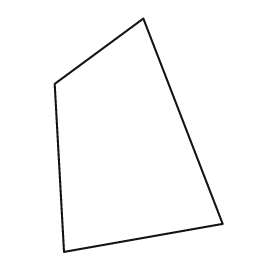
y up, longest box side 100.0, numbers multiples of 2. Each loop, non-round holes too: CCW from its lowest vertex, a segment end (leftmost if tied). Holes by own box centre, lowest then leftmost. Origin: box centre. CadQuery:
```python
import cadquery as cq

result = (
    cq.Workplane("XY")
    .moveTo(-32.0, -50.0)
    .lineTo(36.0, -38.0)
    .lineTo(2.0, 50.0)
    .lineTo(-36.0, 22.0)
    .close()
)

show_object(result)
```